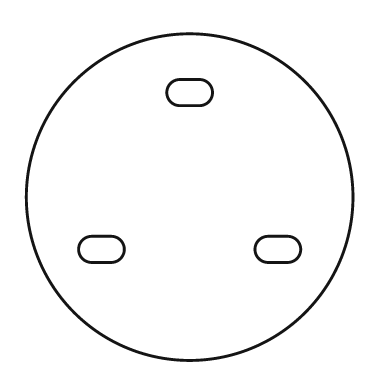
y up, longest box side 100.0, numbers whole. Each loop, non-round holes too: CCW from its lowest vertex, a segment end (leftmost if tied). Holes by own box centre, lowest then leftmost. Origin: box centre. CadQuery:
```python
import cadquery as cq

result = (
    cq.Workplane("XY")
    .moveTo(0.0, 0.0)
    .circle(50.0)
    .moveTo(-30.0, -20.0)
    .lineTo(-24.0, -20.0)
    .threePointArc((-20.0, -16.0), (-24.0, -12.0))
    .lineTo(-30.0, -12.0)
    .threePointArc((-34.0, -16.0), (-30.0, -20.0))
    .close()
    .moveTo(24.0, -20.0)
    .lineTo(30.0, -20.0)
    .threePointArc((34.0, -16.0), (30.0, -12.0))
    .lineTo(24.0, -12.0)
    .threePointArc((20.0, -16.0), (24.0, -20.0))
    .close()
    .moveTo(-3.0, 28.0)
    .lineTo(3.0, 28.0)
    .threePointArc((7.0, 32.0), (3.0, 36.0))
    .lineTo(-3.0, 36.0)
    .threePointArc((-7.0, 32.0), (-3.0, 28.0))
    .close()
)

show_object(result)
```